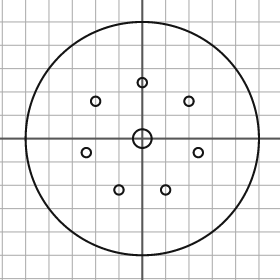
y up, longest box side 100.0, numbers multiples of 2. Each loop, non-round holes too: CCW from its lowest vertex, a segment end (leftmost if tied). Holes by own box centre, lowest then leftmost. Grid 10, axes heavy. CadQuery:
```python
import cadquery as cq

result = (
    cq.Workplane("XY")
    .moveTo(0.0, 0.0)
    .circle(50.0)
    .moveTo(-10.0, -22.0)
    .circle(2.0)
    .moveTo(10.0, -22.0)
    .circle(2.0)
    .moveTo(-24.0, -6.0)
    .circle(2.0)
    .moveTo(24.0, -6.0)
    .circle(2.0)
    .moveTo(0.0, 0.0)
    .circle(4.0)
    .moveTo(-20.0, 16.0)
    .circle(2.0)
    .moveTo(20.0, 16.0)
    .circle(2.0)
    .moveTo(0.0, 24.0)
    .circle(2.0)
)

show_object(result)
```